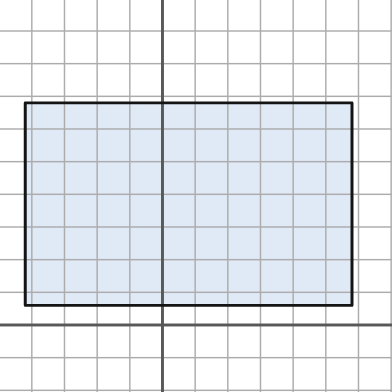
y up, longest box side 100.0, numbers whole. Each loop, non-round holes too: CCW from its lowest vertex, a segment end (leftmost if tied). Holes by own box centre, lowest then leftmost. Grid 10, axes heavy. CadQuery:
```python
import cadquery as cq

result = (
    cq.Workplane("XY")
    .moveTo(-42.0, 6.0)
    .lineTo(58.0, 6.0)
    .lineTo(58.0, 68.0)
    .lineTo(-42.0, 68.0)
    .close()
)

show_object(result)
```